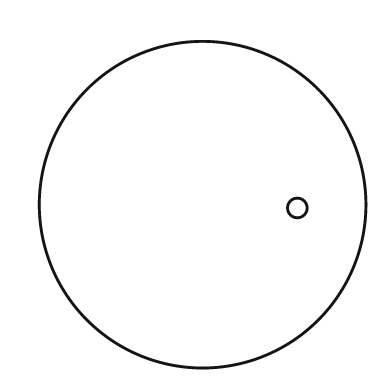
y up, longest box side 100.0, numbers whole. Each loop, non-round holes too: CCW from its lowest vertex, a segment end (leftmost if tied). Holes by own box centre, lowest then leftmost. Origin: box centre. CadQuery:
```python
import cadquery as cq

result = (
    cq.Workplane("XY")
    .moveTo(0.0, 0.0)
    .circle(50.0)
    .moveTo(29.0, -1.0)
    .circle(3.0)
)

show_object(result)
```